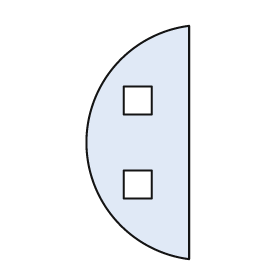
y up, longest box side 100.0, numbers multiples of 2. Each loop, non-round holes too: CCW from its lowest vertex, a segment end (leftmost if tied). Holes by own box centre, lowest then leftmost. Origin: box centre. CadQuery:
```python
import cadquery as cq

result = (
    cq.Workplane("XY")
    .moveTo(22.0, -50.0)
    .lineTo(22.0, 50.0)
    .threePointArc((-22.0, 0.0), (22.0, -50.0))
    .close()
    .moveTo(-6.0, -24.0)
    .lineTo(6.0, -24.0)
    .lineTo(6.0, -12.0)
    .lineTo(-6.0, -12.0)
    .close()
    .moveTo(-6.0, 12.0)
    .lineTo(6.0, 12.0)
    .lineTo(6.0, 24.0)
    .lineTo(-6.0, 24.0)
    .close()
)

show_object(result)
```